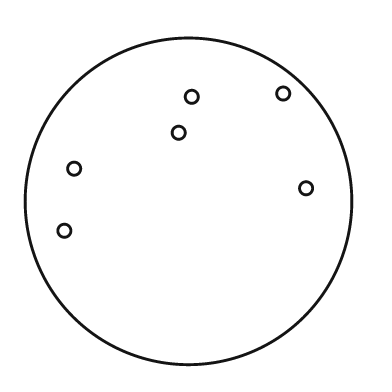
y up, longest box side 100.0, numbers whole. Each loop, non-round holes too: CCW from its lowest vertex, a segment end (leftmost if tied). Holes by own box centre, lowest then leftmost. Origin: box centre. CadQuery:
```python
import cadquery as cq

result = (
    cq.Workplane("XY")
    .moveTo(0.0, 0.0)
    .circle(50.0)
    .moveTo(-38.0, -9.0)
    .circle(2.0)
    .moveTo(36.0, 4.0)
    .circle(2.0)
    .moveTo(-35.0, 10.0)
    .circle(2.0)
    .moveTo(-3.0, 21.0)
    .circle(2.0)
    .moveTo(1.0, 32.0)
    .circle(2.0)
    .moveTo(29.0, 33.0)
    .circle(2.0)
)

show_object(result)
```